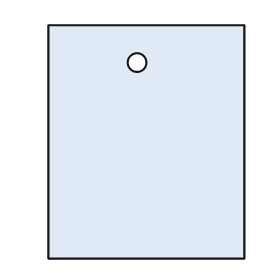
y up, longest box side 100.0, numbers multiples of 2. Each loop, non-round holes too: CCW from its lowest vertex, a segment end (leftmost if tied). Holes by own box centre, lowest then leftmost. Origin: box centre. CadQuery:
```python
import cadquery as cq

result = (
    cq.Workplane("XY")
    .moveTo(-42.0, -50.0)
    .lineTo(42.0, -50.0)
    .lineTo(42.0, 50.0)
    .lineTo(-42.0, 50.0)
    .close()
    .moveTo(-4.0, 34.0)
    .circle(4.0)
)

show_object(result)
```